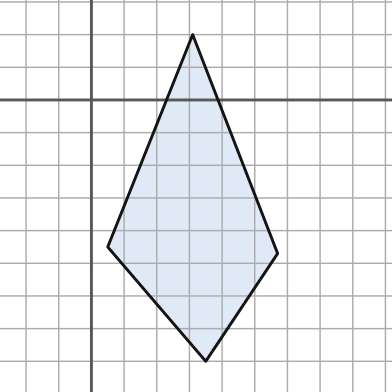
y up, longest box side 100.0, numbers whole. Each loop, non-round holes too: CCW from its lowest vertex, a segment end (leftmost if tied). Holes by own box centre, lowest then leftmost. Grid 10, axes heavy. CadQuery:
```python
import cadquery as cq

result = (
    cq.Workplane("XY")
    .moveTo(35.0, -80.0)
    .lineTo(57.0, -47.0)
    .lineTo(31.0, 20.0)
    .lineTo(5.0, -45.0)
    .close()
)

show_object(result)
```